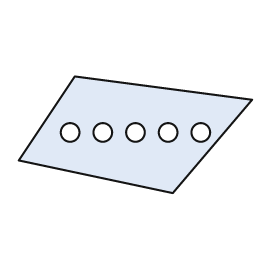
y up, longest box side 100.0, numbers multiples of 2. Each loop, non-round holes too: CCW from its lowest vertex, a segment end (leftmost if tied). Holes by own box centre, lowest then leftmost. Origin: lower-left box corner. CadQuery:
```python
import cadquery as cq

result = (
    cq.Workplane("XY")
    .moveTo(66.0, 0.0)
    .lineTo(100.0, 40.0)
    .lineTo(24.0, 50.0)
    .lineTo(0.0, 14.0)
    .close()
    .moveTo(22.0, 26.0)
    .circle(4.0)
    .moveTo(36.0, 26.0)
    .circle(4.0)
    .moveTo(50.0, 26.0)
    .circle(4.0)
    .moveTo(64.0, 26.0)
    .circle(4.0)
    .moveTo(78.0, 26.0)
    .circle(4.0)
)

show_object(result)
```